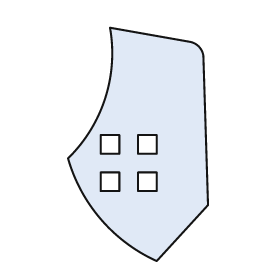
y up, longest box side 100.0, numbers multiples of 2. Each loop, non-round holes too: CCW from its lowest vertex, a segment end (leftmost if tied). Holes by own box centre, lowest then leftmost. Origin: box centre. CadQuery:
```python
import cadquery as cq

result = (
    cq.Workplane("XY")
    .moveTo(8.0, -50.0)
    .lineTo(30.0, -26.0)
    .lineTo(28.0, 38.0)
    .threePointArc((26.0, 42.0), (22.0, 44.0))
    .lineTo(-12.0, 50.0)
    .threePointArc((-14.0, 20.0), (-30.0, -6.0))
    .threePointArc((-16.0, -32.0), (8.0, -50.0))
    .close()
    .moveTo(-16.0, -20.0)
    .lineTo(-8.0, -20.0)
    .lineTo(-8.0, -12.0)
    .lineTo(-16.0, -12.0)
    .close()
    .moveTo(0.0, -20.0)
    .lineTo(8.0, -20.0)
    .lineTo(8.0, -12.0)
    .lineTo(0.0, -12.0)
    .close()
    .moveTo(-16.0, -4.0)
    .lineTo(-8.0, -4.0)
    .lineTo(-8.0, 4.0)
    .lineTo(-16.0, 4.0)
    .close()
    .moveTo(0.0, -4.0)
    .lineTo(8.0, -4.0)
    .lineTo(8.0, 4.0)
    .lineTo(0.0, 4.0)
    .close()
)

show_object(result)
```